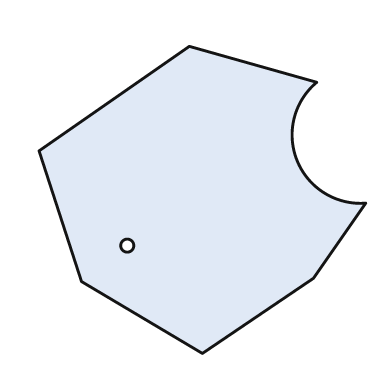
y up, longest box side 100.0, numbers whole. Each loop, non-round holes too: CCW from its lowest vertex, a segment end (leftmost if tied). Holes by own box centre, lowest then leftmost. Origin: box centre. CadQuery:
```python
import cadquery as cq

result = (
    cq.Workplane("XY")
    .moveTo(0.0, -47.0)
    .lineTo(34.0, -24.0)
    .lineTo(50.0, -1.0)
    .threePointArc((29.0, 12.0), (35.0, 36.0))
    .lineTo(-4.0, 47.0)
    .lineTo(-50.0, 15.0)
    .lineTo(-37.0, -25.0)
    .close()
    .moveTo(-23.0, -14.0)
    .circle(2.0)
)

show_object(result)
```